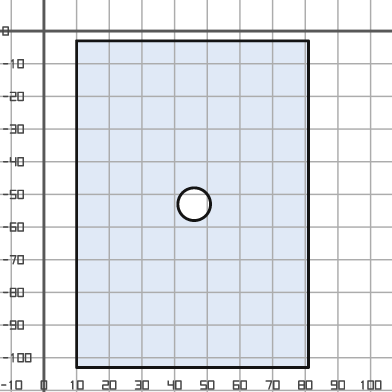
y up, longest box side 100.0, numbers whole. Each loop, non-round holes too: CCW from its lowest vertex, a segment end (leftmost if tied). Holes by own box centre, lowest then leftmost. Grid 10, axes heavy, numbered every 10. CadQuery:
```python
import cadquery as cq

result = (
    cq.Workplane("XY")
    .moveTo(10.0, -103.0)
    .lineTo(81.0, -103.0)
    .lineTo(81.0, -3.0)
    .lineTo(10.0, -3.0)
    .close()
    .moveTo(46.0, -53.0)
    .circle(5.0)
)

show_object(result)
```